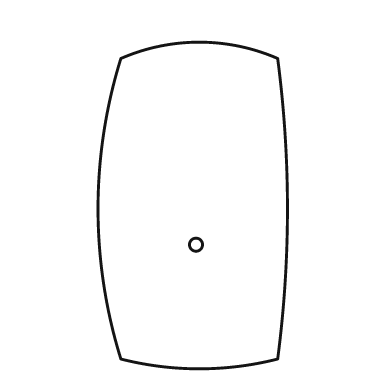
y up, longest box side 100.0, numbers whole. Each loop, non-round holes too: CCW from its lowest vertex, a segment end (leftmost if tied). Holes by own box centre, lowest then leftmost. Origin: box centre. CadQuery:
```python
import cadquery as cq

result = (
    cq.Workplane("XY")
    .moveTo(-22.0, -47.0)
    .threePointArc((2.0, -50.0), (26.0, -47.0))
    .threePointArc((29.0, -1.0), (26.0, 45.0))
    .threePointArc((2.0, 50.0), (-22.0, 45.0))
    .threePointArc((-29.0, -1.0), (-22.0, -47.0))
    .close()
    .moveTo(1.0, -12.0)
    .circle(2.0)
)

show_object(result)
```